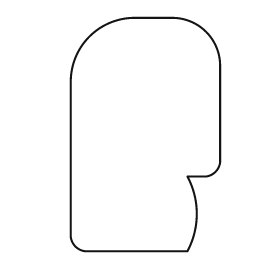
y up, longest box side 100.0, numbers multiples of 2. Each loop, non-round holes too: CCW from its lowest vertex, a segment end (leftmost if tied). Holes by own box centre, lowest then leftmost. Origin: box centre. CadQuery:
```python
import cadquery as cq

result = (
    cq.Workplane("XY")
    .moveTo(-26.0, -50.0)
    .lineTo(18.0, -50.0)
    .threePointArc((22.0, -34.0), (18.0, -18.0))
    .lineTo(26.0, -18.0)
    .threePointArc((30.0, -16.0), (32.0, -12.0))
    .lineTo(32.0, 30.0)
    .threePointArc((26.0, 44.0), (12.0, 50.0))
    .lineTo(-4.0, 50.0)
    .threePointArc((-24.0, 42.0), (-32.0, 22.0))
    .lineTo(-32.0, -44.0)
    .threePointArc((-30.0, -48.0), (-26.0, -50.0))
    .close()
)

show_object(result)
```